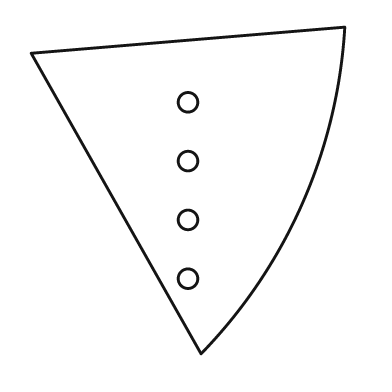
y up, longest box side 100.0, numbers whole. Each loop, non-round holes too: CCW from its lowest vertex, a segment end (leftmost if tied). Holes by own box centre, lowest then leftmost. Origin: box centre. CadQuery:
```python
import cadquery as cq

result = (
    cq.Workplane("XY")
    .moveTo(4.0, -50.0)
    .threePointArc((35.0, -4.0), (48.0, 50.0))
    .lineTo(-48.0, 42.0)
    .close()
    .moveTo(0.0, -27.0)
    .circle(3.0)
    .moveTo(0.0, -9.0)
    .circle(3.0)
    .moveTo(0.0, 9.0)
    .circle(3.0)
    .moveTo(0.0, 27.0)
    .circle(3.0)
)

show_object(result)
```